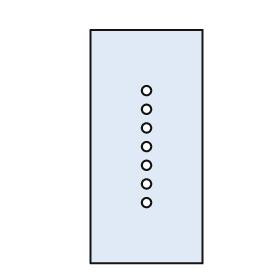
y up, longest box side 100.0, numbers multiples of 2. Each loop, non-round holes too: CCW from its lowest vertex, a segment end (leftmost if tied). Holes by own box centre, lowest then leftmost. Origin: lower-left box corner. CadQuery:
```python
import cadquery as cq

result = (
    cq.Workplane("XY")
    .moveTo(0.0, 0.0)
    .lineTo(48.0, 0.0)
    .lineTo(48.0, 100.0)
    .lineTo(0.0, 100.0)
    .close()
    .moveTo(24.0, 26.0)
    .circle(2.0)
    .moveTo(24.0, 34.0)
    .circle(2.0)
    .moveTo(24.0, 42.0)
    .circle(2.0)
    .moveTo(24.0, 50.0)
    .circle(2.0)
    .moveTo(24.0, 58.0)
    .circle(2.0)
    .moveTo(24.0, 66.0)
    .circle(2.0)
    .moveTo(24.0, 74.0)
    .circle(2.0)
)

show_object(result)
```